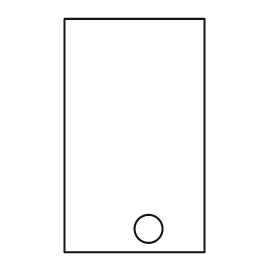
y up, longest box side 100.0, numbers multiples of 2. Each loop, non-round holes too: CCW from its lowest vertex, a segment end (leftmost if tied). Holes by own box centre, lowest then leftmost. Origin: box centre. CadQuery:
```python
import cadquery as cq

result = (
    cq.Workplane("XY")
    .moveTo(-30.0, -50.0)
    .lineTo(30.0, -50.0)
    .lineTo(30.0, 50.0)
    .lineTo(-30.0, 50.0)
    .close()
    .moveTo(6.0, -40.0)
    .circle(6.0)
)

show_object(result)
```